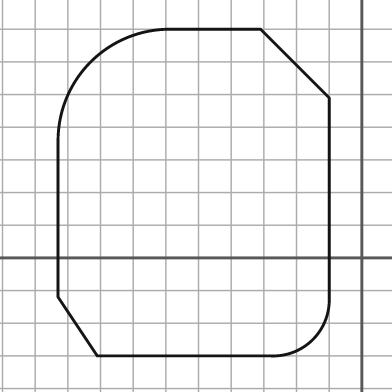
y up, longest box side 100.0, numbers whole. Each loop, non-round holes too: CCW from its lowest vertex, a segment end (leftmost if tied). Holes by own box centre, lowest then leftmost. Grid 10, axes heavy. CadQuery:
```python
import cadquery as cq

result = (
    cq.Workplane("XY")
    .moveTo(-81.0, -30.0)
    .lineTo(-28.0, -30.0)
    .threePointArc((-15.0, -25.0), (-10.0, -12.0))
    .lineTo(-10.0, 49.0)
    .lineTo(-31.0, 70.0)
    .lineTo(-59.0, 70.0)
    .threePointArc((-83.0, 60.0), (-93.0, 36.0))
    .lineTo(-93.0, -12.0)
    .close()
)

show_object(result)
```